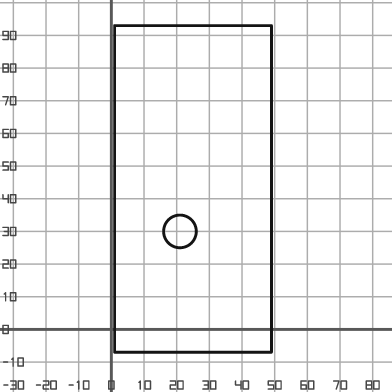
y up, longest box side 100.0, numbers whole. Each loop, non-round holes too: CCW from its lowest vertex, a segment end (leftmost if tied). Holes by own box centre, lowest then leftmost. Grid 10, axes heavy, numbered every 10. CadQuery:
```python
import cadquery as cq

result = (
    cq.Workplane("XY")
    .moveTo(1.0, -7.0)
    .lineTo(49.0, -7.0)
    .lineTo(49.0, 93.0)
    .lineTo(1.0, 93.0)
    .close()
    .moveTo(21.0, 30.0)
    .circle(5.0)
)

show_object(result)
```